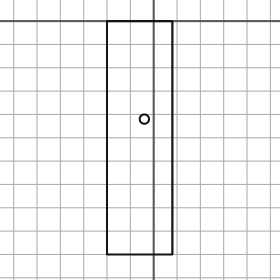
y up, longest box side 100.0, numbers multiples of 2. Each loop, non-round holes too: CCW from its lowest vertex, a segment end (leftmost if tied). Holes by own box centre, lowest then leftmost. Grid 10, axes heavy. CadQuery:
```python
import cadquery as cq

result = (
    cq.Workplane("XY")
    .moveTo(-20.0, -100.0)
    .lineTo(8.0, -100.0)
    .lineTo(8.0, 0.0)
    .lineTo(-20.0, 0.0)
    .close()
    .moveTo(-4.0, -42.0)
    .circle(2.0)
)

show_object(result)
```